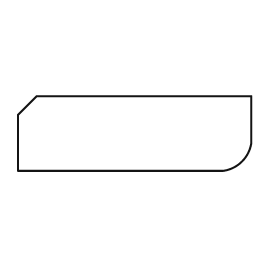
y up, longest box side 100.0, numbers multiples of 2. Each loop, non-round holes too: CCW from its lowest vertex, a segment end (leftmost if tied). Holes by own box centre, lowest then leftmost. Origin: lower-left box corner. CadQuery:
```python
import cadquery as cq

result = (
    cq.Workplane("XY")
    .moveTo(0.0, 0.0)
    .lineTo(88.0, 0.0)
    .threePointArc((96.0, 4.0), (100.0, 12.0))
    .lineTo(100.0, 32.0)
    .lineTo(8.0, 32.0)
    .lineTo(0.0, 24.0)
    .close()
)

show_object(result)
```